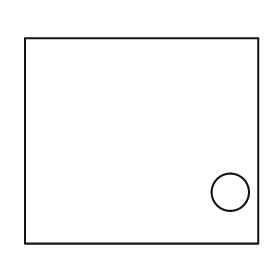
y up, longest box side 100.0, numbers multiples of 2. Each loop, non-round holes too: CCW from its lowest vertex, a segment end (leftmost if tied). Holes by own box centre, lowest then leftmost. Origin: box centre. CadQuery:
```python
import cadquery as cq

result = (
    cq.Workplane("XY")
    .moveTo(-50.0, -44.0)
    .lineTo(50.0, -44.0)
    .lineTo(50.0, 44.0)
    .lineTo(-50.0, 44.0)
    .close()
    .moveTo(38.0, -22.0)
    .circle(8.0)
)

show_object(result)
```